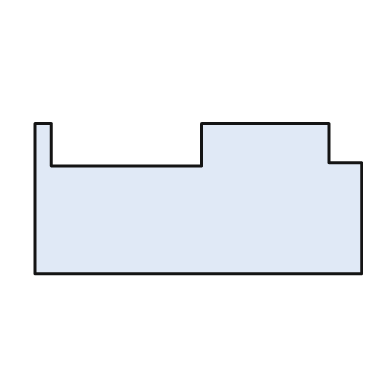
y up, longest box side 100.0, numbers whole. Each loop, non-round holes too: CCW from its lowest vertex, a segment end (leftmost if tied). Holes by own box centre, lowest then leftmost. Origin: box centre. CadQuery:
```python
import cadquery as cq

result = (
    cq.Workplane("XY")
    .moveTo(-50.0, -23.0)
    .lineTo(50.0, -23.0)
    .lineTo(50.0, 11.0)
    .lineTo(40.0, 11.0)
    .lineTo(40.0, 23.0)
    .lineTo(1.0, 23.0)
    .lineTo(1.0, 10.0)
    .lineTo(-45.0, 10.0)
    .lineTo(-45.0, 23.0)
    .lineTo(-50.0, 23.0)
    .close()
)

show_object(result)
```